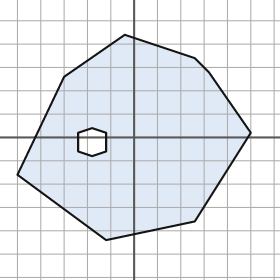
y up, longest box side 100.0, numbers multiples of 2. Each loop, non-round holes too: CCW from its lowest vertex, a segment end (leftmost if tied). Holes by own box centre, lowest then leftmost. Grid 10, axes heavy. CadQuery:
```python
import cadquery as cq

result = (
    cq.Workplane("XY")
    .moveTo(-12.0, -44.0)
    .lineTo(26.0, -36.0)
    .lineTo(50.0, 2.0)
    .lineTo(32.0, 28.0)
    .lineTo(26.0, 34.0)
    .lineTo(-4.0, 44.0)
    .lineTo(-30.0, 26.0)
    .lineTo(-50.0, -16.0)
    .close()
    .moveTo(-18.0, -8.0)
    .lineTo(-12.0, -6.0)
    .lineTo(-12.0, 2.0)
    .lineTo(-18.0, 4.0)
    .lineTo(-24.0, 2.0)
    .lineTo(-24.0, -6.0)
    .close()
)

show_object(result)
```